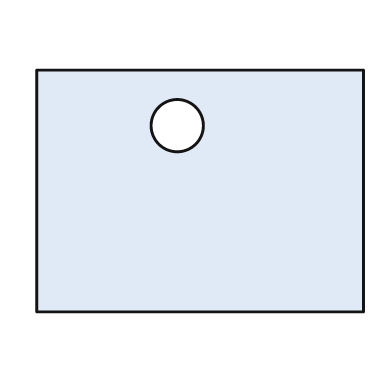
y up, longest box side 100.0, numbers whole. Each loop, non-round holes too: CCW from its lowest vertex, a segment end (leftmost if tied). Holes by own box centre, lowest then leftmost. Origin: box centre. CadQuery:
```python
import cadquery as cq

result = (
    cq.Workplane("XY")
    .moveTo(-50.0, -37.0)
    .lineTo(50.0, -37.0)
    .lineTo(50.0, 37.0)
    .lineTo(-50.0, 37.0)
    .close()
    .moveTo(-7.0, 20.0)
    .circle(8.0)
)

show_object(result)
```